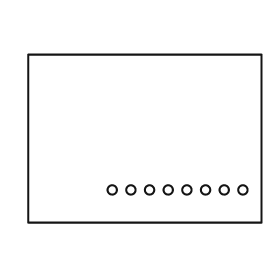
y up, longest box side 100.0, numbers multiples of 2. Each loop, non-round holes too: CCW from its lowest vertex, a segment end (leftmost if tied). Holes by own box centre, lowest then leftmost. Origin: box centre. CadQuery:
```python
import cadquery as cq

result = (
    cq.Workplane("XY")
    .moveTo(-50.0, -36.0)
    .lineTo(50.0, -36.0)
    .lineTo(50.0, 36.0)
    .lineTo(-50.0, 36.0)
    .close()
    .moveTo(-14.0, -22.0)
    .circle(2.0)
    .moveTo(-6.0, -22.0)
    .circle(2.0)
    .moveTo(2.0, -22.0)
    .circle(2.0)
    .moveTo(10.0, -22.0)
    .circle(2.0)
    .moveTo(18.0, -22.0)
    .circle(2.0)
    .moveTo(26.0, -22.0)
    .circle(2.0)
    .moveTo(34.0, -22.0)
    .circle(2.0)
    .moveTo(42.0, -22.0)
    .circle(2.0)
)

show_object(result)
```